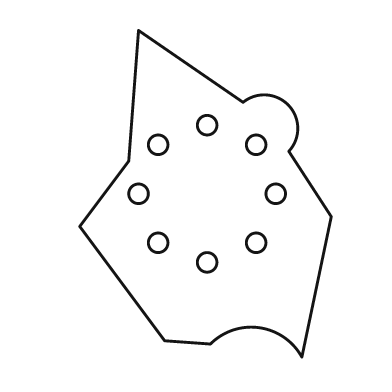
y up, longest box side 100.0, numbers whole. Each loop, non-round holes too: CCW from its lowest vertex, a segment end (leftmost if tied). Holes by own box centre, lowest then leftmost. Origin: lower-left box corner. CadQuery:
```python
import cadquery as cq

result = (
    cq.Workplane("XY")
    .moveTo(68.0, 0.0)
    .lineTo(77.0, 43.0)
    .lineTo(64.0, 63.0)
    .threePointArc((64.0, 77.0), (50.0, 78.0))
    .lineTo(18.0, 100.0)
    .lineTo(15.0, 60.0)
    .lineTo(0.0, 40.0)
    .lineTo(26.0, 5.0)
    .lineTo(40.0, 4.0)
    .threePointArc((55.0, 9.0), (68.0, 0.0))
    .close()
    .moveTo(39.0, 29.0)
    .circle(3.0)
    .moveTo(24.0, 35.0)
    .circle(3.0)
    .moveTo(54.0, 35.0)
    .circle(3.0)
    .moveTo(18.0, 50.0)
    .circle(3.0)
    .moveTo(60.0, 50.0)
    .circle(3.0)
    .moveTo(24.0, 65.0)
    .circle(3.0)
    .moveTo(54.0, 65.0)
    .circle(3.0)
    .moveTo(39.0, 71.0)
    .circle(3.0)
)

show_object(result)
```